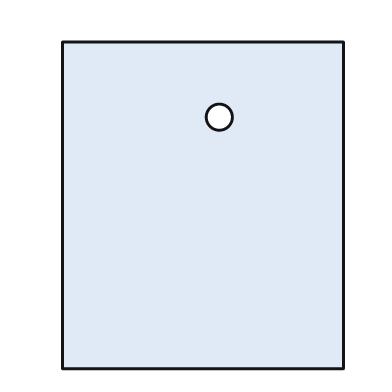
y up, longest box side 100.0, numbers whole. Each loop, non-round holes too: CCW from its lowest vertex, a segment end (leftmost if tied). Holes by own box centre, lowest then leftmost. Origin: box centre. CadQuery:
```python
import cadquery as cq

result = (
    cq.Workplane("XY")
    .moveTo(-43.0, -50.0)
    .lineTo(43.0, -50.0)
    .lineTo(43.0, 50.0)
    .lineTo(-43.0, 50.0)
    .close()
    .moveTo(5.0, 27.0)
    .circle(4.0)
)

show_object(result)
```